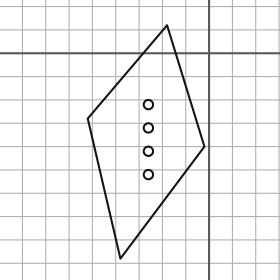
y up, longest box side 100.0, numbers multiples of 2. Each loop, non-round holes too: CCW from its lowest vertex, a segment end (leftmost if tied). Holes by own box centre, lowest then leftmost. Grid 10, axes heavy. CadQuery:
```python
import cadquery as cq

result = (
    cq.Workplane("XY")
    .moveTo(-38.0, -88.0)
    .lineTo(-2.0, -40.0)
    .lineTo(-18.0, 12.0)
    .lineTo(-52.0, -28.0)
    .close()
    .moveTo(-26.0, -52.0)
    .circle(2.0)
    .moveTo(-26.0, -42.0)
    .circle(2.0)
    .moveTo(-26.0, -32.0)
    .circle(2.0)
    .moveTo(-26.0, -22.0)
    .circle(2.0)
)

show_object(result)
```